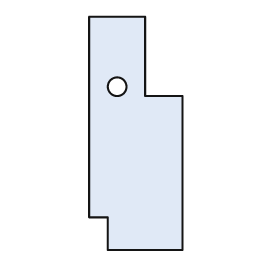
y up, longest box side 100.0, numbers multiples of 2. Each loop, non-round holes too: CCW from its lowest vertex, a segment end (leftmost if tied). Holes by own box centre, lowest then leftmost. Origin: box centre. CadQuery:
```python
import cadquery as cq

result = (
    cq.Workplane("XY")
    .moveTo(-12.0, -50.0)
    .lineTo(20.0, -50.0)
    .lineTo(20.0, 16.0)
    .lineTo(4.0, 16.0)
    .lineTo(4.0, 50.0)
    .lineTo(-20.0, 50.0)
    .lineTo(-20.0, -36.0)
    .lineTo(-12.0, -36.0)
    .close()
    .moveTo(-8.0, 20.0)
    .circle(4.0)
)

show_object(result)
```